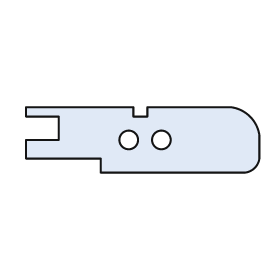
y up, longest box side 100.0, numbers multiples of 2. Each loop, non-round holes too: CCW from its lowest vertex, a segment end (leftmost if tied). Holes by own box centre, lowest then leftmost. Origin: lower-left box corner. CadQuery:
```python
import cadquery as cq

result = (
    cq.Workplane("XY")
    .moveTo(32.0, 0.0)
    .lineTo(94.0, 0.0)
    .threePointArc((98.0, 2.0), (100.0, 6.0))
    .lineTo(100.0, 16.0)
    .threePointArc((96.0, 24.0), (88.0, 28.0))
    .lineTo(52.0, 28.0)
    .lineTo(52.0, 24.0)
    .lineTo(46.0, 24.0)
    .lineTo(46.0, 28.0)
    .lineTo(0.0, 28.0)
    .lineTo(0.0, 24.0)
    .lineTo(14.0, 24.0)
    .lineTo(14.0, 14.0)
    .lineTo(0.0, 14.0)
    .lineTo(0.0, 6.0)
    .lineTo(32.0, 6.0)
    .close()
    .moveTo(44.0, 14.0)
    .circle(4.0)
    .moveTo(58.0, 14.0)
    .circle(4.0)
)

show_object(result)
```